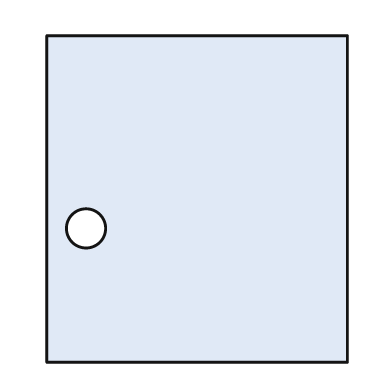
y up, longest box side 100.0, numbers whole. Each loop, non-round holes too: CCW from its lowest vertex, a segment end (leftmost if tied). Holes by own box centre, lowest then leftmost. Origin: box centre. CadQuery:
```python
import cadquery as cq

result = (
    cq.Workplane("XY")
    .moveTo(-46.0, -50.0)
    .lineTo(46.0, -50.0)
    .lineTo(46.0, 50.0)
    .lineTo(-46.0, 50.0)
    .close()
    .moveTo(-34.0, -9.0)
    .circle(6.0)
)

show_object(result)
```